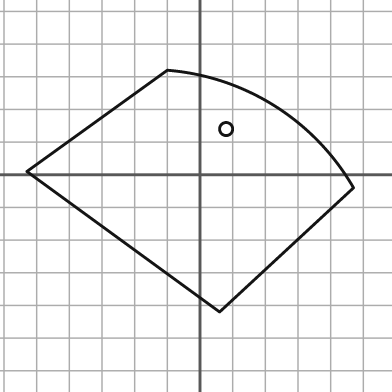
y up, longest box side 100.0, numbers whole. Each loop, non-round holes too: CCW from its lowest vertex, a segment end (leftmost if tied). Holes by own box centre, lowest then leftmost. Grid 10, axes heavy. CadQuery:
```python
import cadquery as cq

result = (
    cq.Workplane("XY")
    .moveTo(6.0, -42.0)
    .lineTo(47.0, -4.0)
    .threePointArc((23.0, 21.0), (-10.0, 32.0))
    .lineTo(-53.0, 1.0)
    .close()
    .moveTo(8.0, 14.0)
    .circle(2.0)
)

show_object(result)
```